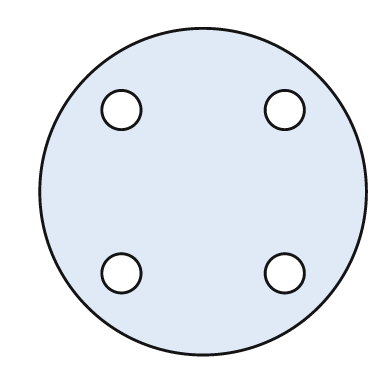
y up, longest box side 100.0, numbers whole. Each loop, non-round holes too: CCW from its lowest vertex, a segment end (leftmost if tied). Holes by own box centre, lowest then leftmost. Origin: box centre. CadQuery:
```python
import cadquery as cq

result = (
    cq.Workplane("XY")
    .moveTo(0.0, 0.0)
    .circle(50.0)
    .moveTo(-25.0, -25.0)
    .circle(6.0)
    .moveTo(25.0, -25.0)
    .circle(6.0)
    .moveTo(-25.0, 25.0)
    .circle(6.0)
    .moveTo(25.0, 25.0)
    .circle(6.0)
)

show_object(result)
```